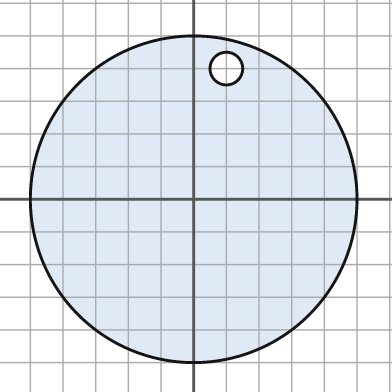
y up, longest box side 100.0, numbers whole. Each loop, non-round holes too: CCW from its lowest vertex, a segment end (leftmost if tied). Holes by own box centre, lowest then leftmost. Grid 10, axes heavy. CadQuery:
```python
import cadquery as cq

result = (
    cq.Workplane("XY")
    .moveTo(0.0, 0.0)
    .circle(50.0)
    .moveTo(10.0, 40.0)
    .circle(5.0)
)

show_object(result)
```